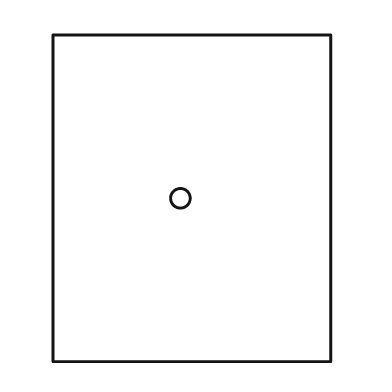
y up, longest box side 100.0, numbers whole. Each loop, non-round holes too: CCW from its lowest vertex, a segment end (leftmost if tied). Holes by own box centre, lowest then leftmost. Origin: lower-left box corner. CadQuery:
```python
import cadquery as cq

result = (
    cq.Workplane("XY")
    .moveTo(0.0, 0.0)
    .lineTo(85.0, 0.0)
    .lineTo(85.0, 100.0)
    .lineTo(0.0, 100.0)
    .close()
    .moveTo(39.0, 50.0)
    .circle(3.0)
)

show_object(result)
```